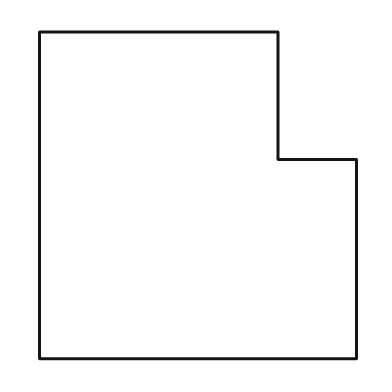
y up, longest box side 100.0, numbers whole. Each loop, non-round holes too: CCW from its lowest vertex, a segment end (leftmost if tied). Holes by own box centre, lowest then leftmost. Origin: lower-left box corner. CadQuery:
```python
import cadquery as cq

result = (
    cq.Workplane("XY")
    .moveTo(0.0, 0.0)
    .lineTo(97.0, 0.0)
    .lineTo(97.0, 61.0)
    .lineTo(73.0, 61.0)
    .lineTo(73.0, 100.0)
    .lineTo(0.0, 100.0)
    .close()
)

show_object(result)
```